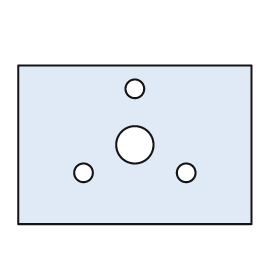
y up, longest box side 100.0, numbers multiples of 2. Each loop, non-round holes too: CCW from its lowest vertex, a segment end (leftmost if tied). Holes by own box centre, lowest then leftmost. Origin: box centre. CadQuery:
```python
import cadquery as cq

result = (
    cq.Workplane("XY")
    .moveTo(-50.0, -34.0)
    .lineTo(50.0, -34.0)
    .lineTo(50.0, 34.0)
    .lineTo(-50.0, 34.0)
    .close()
    .moveTo(-22.0, -12.0)
    .circle(4.0)
    .moveTo(22.0, -12.0)
    .circle(4.0)
    .moveTo(0.0, 0.0)
    .circle(8.0)
    .moveTo(0.0, 24.0)
    .circle(4.0)
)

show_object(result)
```